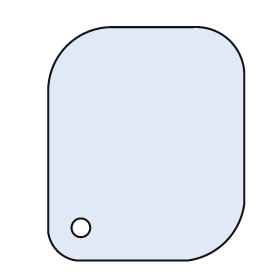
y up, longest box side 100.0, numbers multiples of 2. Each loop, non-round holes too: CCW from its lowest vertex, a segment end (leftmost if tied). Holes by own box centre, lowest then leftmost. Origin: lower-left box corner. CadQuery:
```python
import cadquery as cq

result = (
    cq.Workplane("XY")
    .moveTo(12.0, 0.0)
    .lineTo(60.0, 0.0)
    .threePointArc((76.0, 8.0), (84.0, 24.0))
    .lineTo(84.0, 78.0)
    .threePointArc((78.0, 94.0), (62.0, 100.0))
    .lineTo(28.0, 100.0)
    .threePointArc((8.0, 92.0), (0.0, 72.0))
    .lineTo(0.0, 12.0)
    .threePointArc((4.0, 4.0), (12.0, 0.0))
    .close()
    .moveTo(14.0, 14.0)
    .circle(4.0)
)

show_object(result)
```